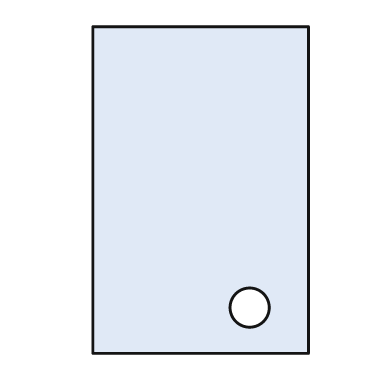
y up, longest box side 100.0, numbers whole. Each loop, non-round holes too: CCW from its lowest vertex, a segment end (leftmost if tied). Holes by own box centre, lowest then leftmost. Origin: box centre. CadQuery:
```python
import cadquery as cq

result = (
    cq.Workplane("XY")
    .moveTo(-33.0, -50.0)
    .lineTo(33.0, -50.0)
    .lineTo(33.0, 50.0)
    .lineTo(-33.0, 50.0)
    .close()
    .moveTo(15.0, -36.0)
    .circle(6.0)
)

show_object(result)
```